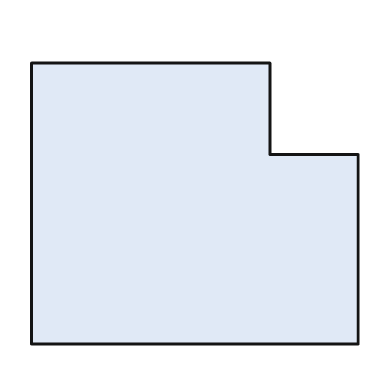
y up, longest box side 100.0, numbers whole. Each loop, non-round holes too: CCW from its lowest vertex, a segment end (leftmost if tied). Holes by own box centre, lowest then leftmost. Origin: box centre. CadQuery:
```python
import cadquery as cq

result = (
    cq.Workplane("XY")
    .moveTo(-50.0, -43.0)
    .lineTo(50.0, -43.0)
    .lineTo(50.0, 15.0)
    .lineTo(23.0, 15.0)
    .lineTo(23.0, 43.0)
    .lineTo(-50.0, 43.0)
    .close()
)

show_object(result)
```